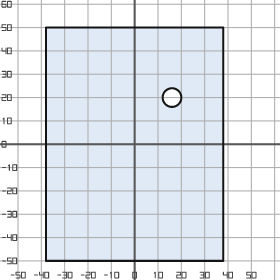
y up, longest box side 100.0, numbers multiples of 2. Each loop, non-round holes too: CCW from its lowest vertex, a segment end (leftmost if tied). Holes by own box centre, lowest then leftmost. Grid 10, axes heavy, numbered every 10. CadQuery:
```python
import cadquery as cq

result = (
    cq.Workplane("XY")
    .moveTo(-38.0, -50.0)
    .lineTo(38.0, -50.0)
    .lineTo(38.0, 50.0)
    .lineTo(-38.0, 50.0)
    .close()
    .moveTo(16.0, 20.0)
    .circle(4.0)
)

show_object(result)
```